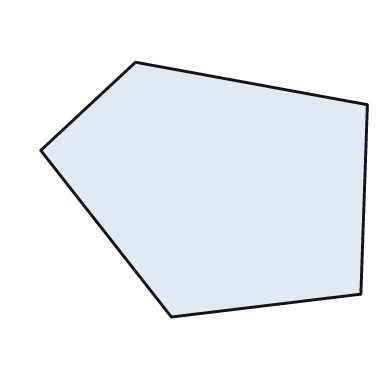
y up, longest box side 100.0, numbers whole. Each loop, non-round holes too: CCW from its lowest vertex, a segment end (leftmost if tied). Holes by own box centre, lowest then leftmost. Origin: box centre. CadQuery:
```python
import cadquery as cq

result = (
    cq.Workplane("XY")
    .moveTo(-10.0, -39.0)
    .lineTo(48.0, -32.0)
    .lineTo(50.0, 26.0)
    .lineTo(-21.0, 39.0)
    .lineTo(-50.0, 12.0)
    .close()
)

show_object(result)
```